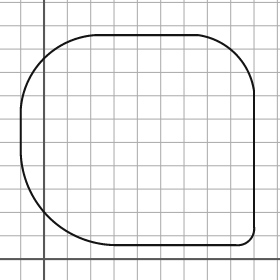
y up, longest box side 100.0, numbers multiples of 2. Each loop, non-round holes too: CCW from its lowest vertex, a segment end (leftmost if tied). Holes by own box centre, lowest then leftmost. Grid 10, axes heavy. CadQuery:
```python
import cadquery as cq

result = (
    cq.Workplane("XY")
    .moveTo(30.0, 6.0)
    .lineTo(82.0, 6.0)
    .threePointArc((88.0, 8.0), (90.0, 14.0))
    .lineTo(90.0, 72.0)
    .threePointArc((82.0, 88.0), (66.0, 96.0))
    .lineTo(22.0, 96.0)
    .threePointArc((0.0, 86.0), (-10.0, 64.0))
    .lineTo(-10.0, 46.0)
    .threePointArc((2.0, 18.0), (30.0, 6.0))
    .close()
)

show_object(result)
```